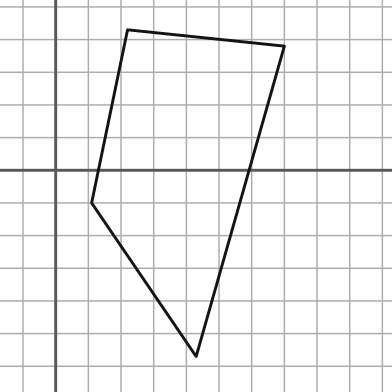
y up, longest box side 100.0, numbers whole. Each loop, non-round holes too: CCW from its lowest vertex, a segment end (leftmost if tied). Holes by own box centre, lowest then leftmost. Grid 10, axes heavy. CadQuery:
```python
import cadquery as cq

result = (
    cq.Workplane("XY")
    .moveTo(43.0, -57.0)
    .lineTo(70.0, 38.0)
    .lineTo(22.0, 43.0)
    .lineTo(11.0, -10.0)
    .close()
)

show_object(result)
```